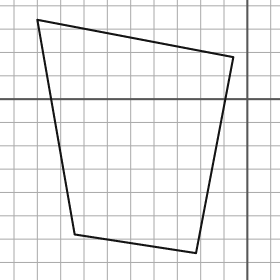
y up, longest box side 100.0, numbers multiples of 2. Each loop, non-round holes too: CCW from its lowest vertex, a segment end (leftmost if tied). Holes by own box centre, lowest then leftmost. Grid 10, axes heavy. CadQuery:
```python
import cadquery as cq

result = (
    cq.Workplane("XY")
    .moveTo(-22.0, -66.0)
    .lineTo(-6.0, 18.0)
    .lineTo(-90.0, 34.0)
    .lineTo(-74.0, -58.0)
    .close()
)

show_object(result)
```